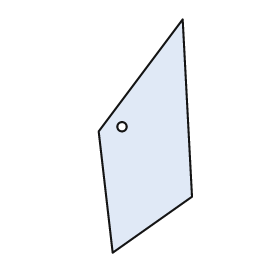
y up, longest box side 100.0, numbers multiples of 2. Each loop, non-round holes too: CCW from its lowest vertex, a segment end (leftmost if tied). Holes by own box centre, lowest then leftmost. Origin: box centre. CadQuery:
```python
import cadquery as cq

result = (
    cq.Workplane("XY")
    .moveTo(-14.0, -50.0)
    .lineTo(20.0, -26.0)
    .lineTo(16.0, 50.0)
    .lineTo(-20.0, 2.0)
    .close()
    .moveTo(-10.0, 4.0)
    .circle(2.0)
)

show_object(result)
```